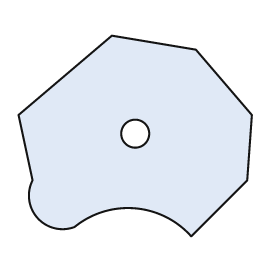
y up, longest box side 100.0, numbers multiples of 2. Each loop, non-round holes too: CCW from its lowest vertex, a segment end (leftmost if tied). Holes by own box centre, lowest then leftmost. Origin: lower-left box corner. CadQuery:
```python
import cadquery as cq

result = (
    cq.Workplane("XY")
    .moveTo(74.0, 0.0)
    .lineTo(98.0, 24.0)
    .lineTo(100.0, 52.0)
    .lineTo(76.0, 80.0)
    .lineTo(40.0, 86.0)
    .lineTo(0.0, 52.0)
    .lineTo(6.0, 24.0)
    .threePointArc((8.0, 8.0), (24.0, 4.0))
    .threePointArc((50.0, 12.0), (74.0, 0.0))
    .close()
    .moveTo(50.0, 44.0)
    .circle(6.0)
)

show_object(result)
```